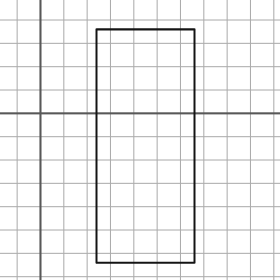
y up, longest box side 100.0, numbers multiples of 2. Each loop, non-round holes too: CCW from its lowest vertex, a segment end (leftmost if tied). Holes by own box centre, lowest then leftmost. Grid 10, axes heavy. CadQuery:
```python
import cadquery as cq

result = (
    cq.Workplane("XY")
    .moveTo(24.0, -64.0)
    .lineTo(66.0, -64.0)
    .lineTo(66.0, 36.0)
    .lineTo(24.0, 36.0)
    .close()
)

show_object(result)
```